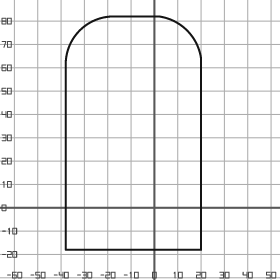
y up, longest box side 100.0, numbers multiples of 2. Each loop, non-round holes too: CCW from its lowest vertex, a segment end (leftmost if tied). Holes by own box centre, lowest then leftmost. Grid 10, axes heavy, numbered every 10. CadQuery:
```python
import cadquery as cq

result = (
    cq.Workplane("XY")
    .moveTo(-38.0, -18.0)
    .lineTo(20.0, -18.0)
    .lineTo(20.0, 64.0)
    .threePointArc((14.0, 76.0), (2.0, 82.0))
    .lineTo(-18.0, 82.0)
    .threePointArc((-32.0, 76.0), (-38.0, 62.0))
    .close()
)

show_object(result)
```